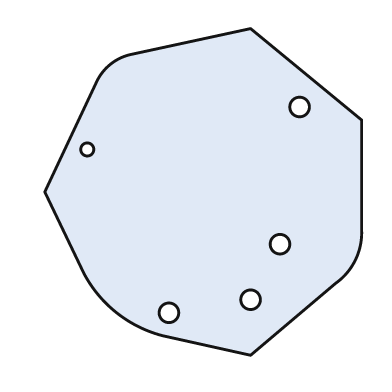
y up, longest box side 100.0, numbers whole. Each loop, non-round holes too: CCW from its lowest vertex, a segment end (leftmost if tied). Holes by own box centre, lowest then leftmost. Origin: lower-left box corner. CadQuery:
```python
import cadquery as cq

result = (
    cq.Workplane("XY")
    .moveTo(63.0, 0.0)
    .lineTo(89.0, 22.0)
    .threePointArc((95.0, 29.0), (97.0, 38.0))
    .lineTo(97.0, 72.0)
    .lineTo(63.0, 100.0)
    .lineTo(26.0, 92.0)
    .threePointArc((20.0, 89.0), (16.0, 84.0))
    .lineTo(0.0, 50.0)
    .lineTo(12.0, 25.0)
    .threePointArc((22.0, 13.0), (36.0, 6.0))
    .close()
    .moveTo(38.0, 13.0)
    .circle(3.0)
    .moveTo(63.0, 17.0)
    .circle(3.0)
    .moveTo(72.0, 34.0)
    .circle(3.0)
    .moveTo(13.0, 63.0)
    .circle(2.0)
    .moveTo(78.0, 76.0)
    .circle(3.0)
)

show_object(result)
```